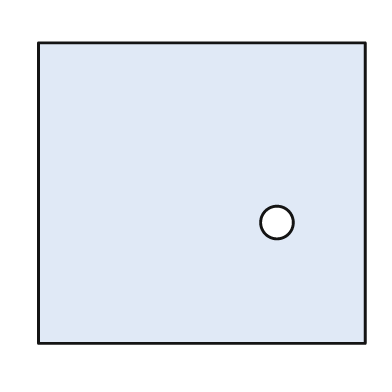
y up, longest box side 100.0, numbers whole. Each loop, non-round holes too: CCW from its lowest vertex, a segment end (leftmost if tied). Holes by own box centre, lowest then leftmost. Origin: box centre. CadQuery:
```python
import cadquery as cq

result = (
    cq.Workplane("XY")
    .moveTo(-50.0, -46.0)
    .lineTo(50.0, -46.0)
    .lineTo(50.0, 46.0)
    .lineTo(-50.0, 46.0)
    .close()
    .moveTo(23.0, -9.0)
    .circle(5.0)
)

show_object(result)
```